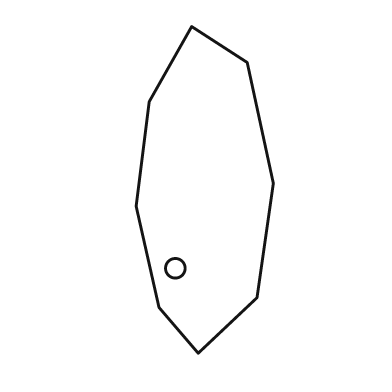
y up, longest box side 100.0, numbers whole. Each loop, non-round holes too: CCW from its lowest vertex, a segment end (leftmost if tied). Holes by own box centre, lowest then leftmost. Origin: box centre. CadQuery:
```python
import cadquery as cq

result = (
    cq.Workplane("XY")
    .moveTo(-2.0, -50.0)
    .lineTo(16.0, -33.0)
    .lineTo(21.0, 2.0)
    .lineTo(13.0, 39.0)
    .lineTo(-4.0, 50.0)
    .lineTo(-17.0, 27.0)
    .lineTo(-21.0, -5.0)
    .lineTo(-14.0, -36.0)
    .close()
    .moveTo(-9.0, -24.0)
    .circle(3.0)
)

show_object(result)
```